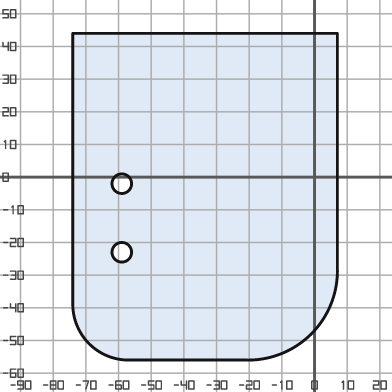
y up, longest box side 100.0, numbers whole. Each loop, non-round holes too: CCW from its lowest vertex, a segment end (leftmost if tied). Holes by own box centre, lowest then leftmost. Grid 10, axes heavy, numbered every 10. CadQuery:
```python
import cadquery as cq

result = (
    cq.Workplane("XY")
    .moveTo(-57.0, -56.0)
    .lineTo(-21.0, -56.0)
    .threePointArc((-1.0, -48.0), (7.0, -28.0))
    .lineTo(7.0, 44.0)
    .lineTo(-74.0, 44.0)
    .lineTo(-74.0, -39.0)
    .threePointArc((-69.0, -51.0), (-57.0, -56.0))
    .close()
    .moveTo(-59.0, -23.0)
    .circle(3.0)
    .moveTo(-59.0, -2.0)
    .circle(3.0)
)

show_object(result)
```